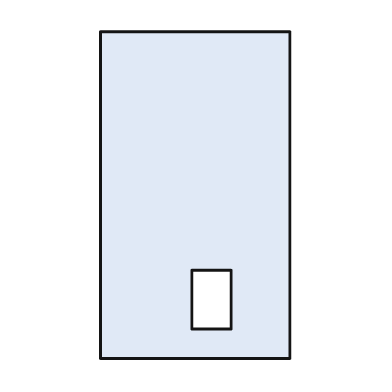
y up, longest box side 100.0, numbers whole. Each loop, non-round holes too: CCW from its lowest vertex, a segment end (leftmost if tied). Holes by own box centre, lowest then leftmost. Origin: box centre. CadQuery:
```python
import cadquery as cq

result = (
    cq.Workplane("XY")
    .moveTo(-29.0, -50.0)
    .lineTo(29.0, -50.0)
    .lineTo(29.0, 50.0)
    .lineTo(-29.0, 50.0)
    .close()
    .moveTo(-1.0, -41.0)
    .lineTo(11.0, -41.0)
    .lineTo(11.0, -23.0)
    .lineTo(-1.0, -23.0)
    .close()
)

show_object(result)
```